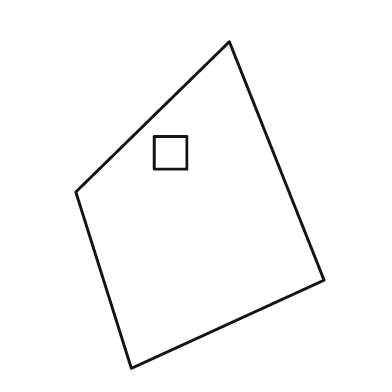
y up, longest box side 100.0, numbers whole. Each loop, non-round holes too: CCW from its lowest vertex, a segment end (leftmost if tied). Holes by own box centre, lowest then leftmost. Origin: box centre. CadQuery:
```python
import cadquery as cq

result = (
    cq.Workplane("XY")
    .moveTo(-21.0, -50.0)
    .lineTo(38.0, -23.0)
    .lineTo(9.0, 50.0)
    .lineTo(-38.0, 4.0)
    .close()
    .moveTo(-14.0, 11.0)
    .lineTo(-4.0, 11.0)
    .lineTo(-4.0, 21.0)
    .lineTo(-14.0, 21.0)
    .close()
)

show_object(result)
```